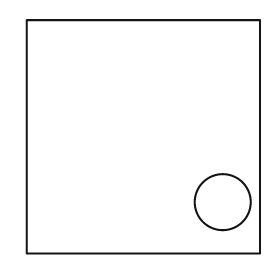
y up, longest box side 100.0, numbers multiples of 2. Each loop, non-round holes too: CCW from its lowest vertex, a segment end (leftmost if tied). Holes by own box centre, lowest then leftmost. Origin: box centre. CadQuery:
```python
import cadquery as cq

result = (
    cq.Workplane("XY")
    .moveTo(-50.0, -50.0)
    .lineTo(50.0, -50.0)
    .lineTo(50.0, 50.0)
    .lineTo(-50.0, 50.0)
    .close()
    .moveTo(34.0, -28.0)
    .circle(12.0)
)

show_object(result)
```